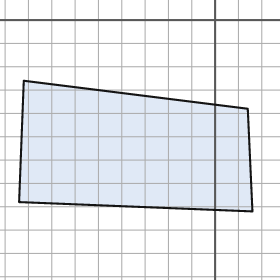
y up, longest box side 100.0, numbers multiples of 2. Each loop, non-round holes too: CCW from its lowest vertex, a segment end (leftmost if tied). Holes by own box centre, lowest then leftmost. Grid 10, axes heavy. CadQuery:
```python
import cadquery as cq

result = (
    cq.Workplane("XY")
    .moveTo(16.0, -82.0)
    .lineTo(14.0, -38.0)
    .lineTo(-82.0, -26.0)
    .lineTo(-84.0, -78.0)
    .close()
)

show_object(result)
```